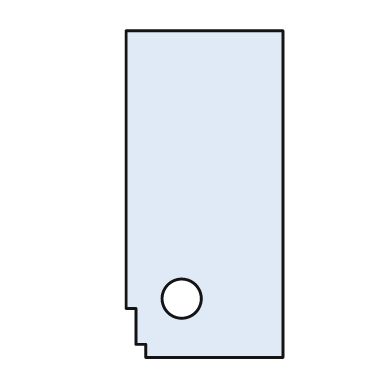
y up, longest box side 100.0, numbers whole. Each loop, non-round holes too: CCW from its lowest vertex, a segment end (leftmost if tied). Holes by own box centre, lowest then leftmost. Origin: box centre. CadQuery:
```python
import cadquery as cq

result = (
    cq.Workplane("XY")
    .moveTo(-18.0, -50.0)
    .lineTo(24.0, -50.0)
    .lineTo(24.0, 50.0)
    .lineTo(-24.0, 50.0)
    .lineTo(-24.0, -35.0)
    .lineTo(-21.0, -35.0)
    .lineTo(-21.0, -46.0)
    .lineTo(-18.0, -46.0)
    .close()
    .moveTo(-7.0, -32.0)
    .circle(6.0)
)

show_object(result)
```